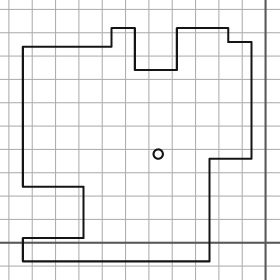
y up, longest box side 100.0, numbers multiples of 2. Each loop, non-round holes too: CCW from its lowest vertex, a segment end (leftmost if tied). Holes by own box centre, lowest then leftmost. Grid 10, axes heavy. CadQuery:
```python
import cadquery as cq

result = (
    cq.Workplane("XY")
    .moveTo(-104.0, -8.0)
    .lineTo(-24.0, -8.0)
    .lineTo(-24.0, 36.0)
    .lineTo(-6.0, 36.0)
    .lineTo(-6.0, 86.0)
    .lineTo(-16.0, 86.0)
    .lineTo(-16.0, 92.0)
    .lineTo(-38.0, 92.0)
    .lineTo(-38.0, 74.0)
    .lineTo(-56.0, 74.0)
    .lineTo(-56.0, 92.0)
    .lineTo(-66.0, 92.0)
    .lineTo(-66.0, 84.0)
    .lineTo(-104.0, 84.0)
    .lineTo(-104.0, 24.0)
    .lineTo(-78.0, 24.0)
    .lineTo(-78.0, 2.0)
    .lineTo(-104.0, 2.0)
    .close()
    .moveTo(-46.0, 38.0)
    .circle(2.0)
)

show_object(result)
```